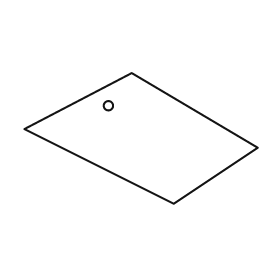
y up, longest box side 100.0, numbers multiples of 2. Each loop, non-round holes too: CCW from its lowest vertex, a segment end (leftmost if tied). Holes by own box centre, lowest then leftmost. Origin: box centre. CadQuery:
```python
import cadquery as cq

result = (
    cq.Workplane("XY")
    .moveTo(14.0, -28.0)
    .lineTo(50.0, -4.0)
    .lineTo(-4.0, 28.0)
    .lineTo(-50.0, 4.0)
    .close()
    .moveTo(-14.0, 14.0)
    .circle(2.0)
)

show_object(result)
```